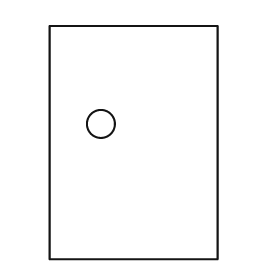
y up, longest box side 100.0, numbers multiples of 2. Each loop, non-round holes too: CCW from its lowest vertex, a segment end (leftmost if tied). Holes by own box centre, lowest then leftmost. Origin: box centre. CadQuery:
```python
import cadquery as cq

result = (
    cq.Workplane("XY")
    .moveTo(-36.0, -50.0)
    .lineTo(36.0, -50.0)
    .lineTo(36.0, 50.0)
    .lineTo(-36.0, 50.0)
    .close()
    .moveTo(-14.0, 8.0)
    .circle(6.0)
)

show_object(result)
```